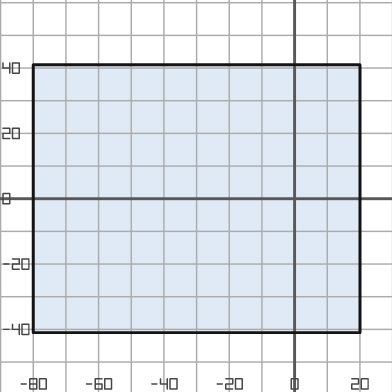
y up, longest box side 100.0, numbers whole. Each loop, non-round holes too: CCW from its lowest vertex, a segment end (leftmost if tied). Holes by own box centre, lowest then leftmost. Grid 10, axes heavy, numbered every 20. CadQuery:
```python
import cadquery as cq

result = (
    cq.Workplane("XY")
    .moveTo(-80.0, -41.0)
    .lineTo(20.0, -41.0)
    .lineTo(20.0, 41.0)
    .lineTo(-80.0, 41.0)
    .close()
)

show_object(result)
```